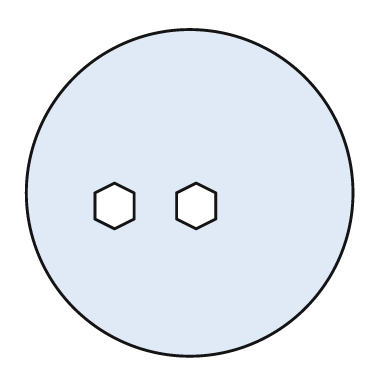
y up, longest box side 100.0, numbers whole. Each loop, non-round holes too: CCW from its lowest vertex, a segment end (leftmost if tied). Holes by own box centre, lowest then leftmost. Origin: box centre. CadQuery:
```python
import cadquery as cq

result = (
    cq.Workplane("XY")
    .moveTo(0.0, 0.0)
    .circle(50.0)
    .moveTo(-23.0, -11.0)
    .lineTo(-17.0, -8.0)
    .lineTo(-17.0, 0.0)
    .lineTo(-23.0, 3.0)
    .lineTo(-29.0, 0.0)
    .lineTo(-29.0, -8.0)
    .close()
    .moveTo(2.0, -11.0)
    .lineTo(8.0, -8.0)
    .lineTo(8.0, 0.0)
    .lineTo(2.0, 3.0)
    .lineTo(-4.0, 0.0)
    .lineTo(-4.0, -8.0)
    .close()
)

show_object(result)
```